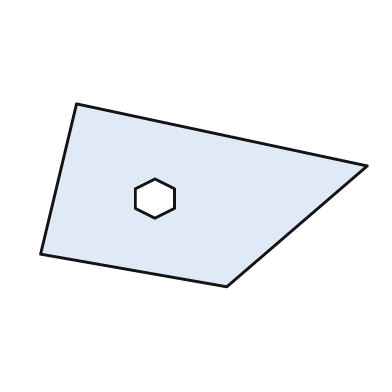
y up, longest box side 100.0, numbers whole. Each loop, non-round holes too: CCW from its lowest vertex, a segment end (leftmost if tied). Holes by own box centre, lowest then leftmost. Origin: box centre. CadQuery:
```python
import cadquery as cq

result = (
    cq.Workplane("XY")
    .moveTo(7.0, -28.0)
    .lineTo(50.0, 9.0)
    .lineTo(-39.0, 28.0)
    .lineTo(-50.0, -18.0)
    .close()
    .moveTo(-15.0, -7.0)
    .lineTo(-9.0, -4.0)
    .lineTo(-9.0, 2.0)
    .lineTo(-15.0, 5.0)
    .lineTo(-21.0, 2.0)
    .lineTo(-21.0, -4.0)
    .close()
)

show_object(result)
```